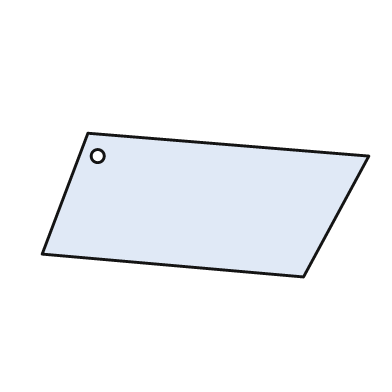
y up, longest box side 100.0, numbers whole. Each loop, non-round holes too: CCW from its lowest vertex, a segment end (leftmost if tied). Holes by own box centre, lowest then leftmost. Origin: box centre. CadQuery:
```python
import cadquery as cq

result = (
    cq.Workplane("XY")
    .moveTo(30.0, -22.0)
    .lineTo(50.0, 15.0)
    .lineTo(-36.0, 22.0)
    .lineTo(-50.0, -15.0)
    .close()
    .moveTo(-33.0, 15.0)
    .circle(2.0)
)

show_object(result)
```